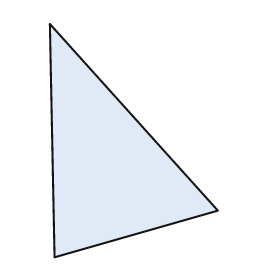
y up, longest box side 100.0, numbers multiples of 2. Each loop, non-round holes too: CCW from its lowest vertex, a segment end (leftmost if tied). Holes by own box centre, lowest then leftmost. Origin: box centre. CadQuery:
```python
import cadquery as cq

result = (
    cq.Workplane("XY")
    .moveTo(-34.0, -50.0)
    .lineTo(36.0, -30.0)
    .lineTo(-36.0, 50.0)
    .close()
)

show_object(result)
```